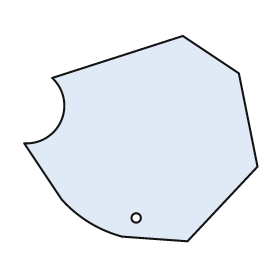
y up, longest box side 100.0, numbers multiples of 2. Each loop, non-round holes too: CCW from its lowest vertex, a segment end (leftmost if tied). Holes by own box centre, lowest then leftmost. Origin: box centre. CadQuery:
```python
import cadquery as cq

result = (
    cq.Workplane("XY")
    .moveTo(20.0, -44.0)
    .lineTo(50.0, -12.0)
    .lineTo(42.0, 28.0)
    .lineTo(18.0, 44.0)
    .lineTo(-38.0, 26.0)
    .threePointArc((-34.0, 8.0), (-50.0, -2.0))
    .lineTo(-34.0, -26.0)
    .threePointArc((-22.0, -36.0), (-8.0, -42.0))
    .close()
    .moveTo(-2.0, -34.0)
    .circle(2.0)
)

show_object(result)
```